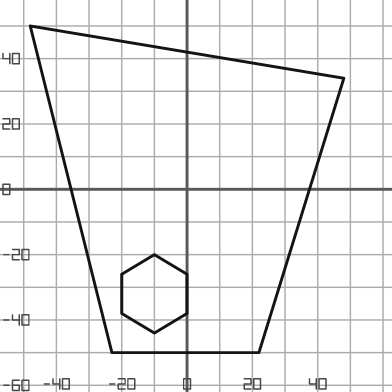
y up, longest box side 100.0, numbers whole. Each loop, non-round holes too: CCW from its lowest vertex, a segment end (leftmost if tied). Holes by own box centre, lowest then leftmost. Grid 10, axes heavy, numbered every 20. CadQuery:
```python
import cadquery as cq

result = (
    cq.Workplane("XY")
    .moveTo(-23.0, -50.0)
    .lineTo(22.0, -50.0)
    .lineTo(48.0, 34.0)
    .lineTo(-48.0, 50.0)
    .close()
    .moveTo(-10.0, -44.0)
    .lineTo(0.0, -38.0)
    .lineTo(0.0, -26.0)
    .lineTo(-10.0, -20.0)
    .lineTo(-20.0, -26.0)
    .lineTo(-20.0, -38.0)
    .close()
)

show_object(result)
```